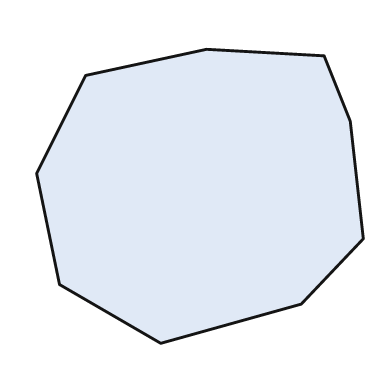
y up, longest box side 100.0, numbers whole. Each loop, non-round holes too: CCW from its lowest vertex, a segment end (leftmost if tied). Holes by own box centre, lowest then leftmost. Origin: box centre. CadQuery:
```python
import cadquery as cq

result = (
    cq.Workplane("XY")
    .moveTo(-12.0, -45.0)
    .lineTo(31.0, -33.0)
    .lineTo(50.0, -13.0)
    .lineTo(46.0, 23.0)
    .lineTo(38.0, 43.0)
    .lineTo(2.0, 45.0)
    .lineTo(-35.0, 37.0)
    .lineTo(-50.0, 7.0)
    .lineTo(-43.0, -27.0)
    .close()
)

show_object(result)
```